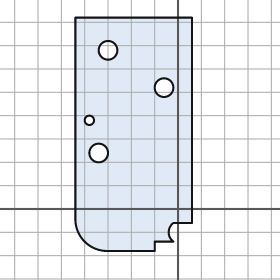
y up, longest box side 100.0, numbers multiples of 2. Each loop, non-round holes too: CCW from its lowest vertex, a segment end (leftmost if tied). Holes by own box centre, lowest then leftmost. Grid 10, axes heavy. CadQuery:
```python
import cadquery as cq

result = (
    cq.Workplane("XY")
    .moveTo(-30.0, -18.0)
    .lineTo(-10.0, -18.0)
    .lineTo(-10.0, -14.0)
    .lineTo(-2.0, -14.0)
    .threePointArc((-4.0, -10.0), (-2.0, -6.0))
    .lineTo(6.0, -6.0)
    .lineTo(6.0, 82.0)
    .lineTo(-44.0, 82.0)
    .lineTo(-44.0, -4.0)
    .threePointArc((-40.0, -14.0), (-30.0, -18.0))
    .close()
    .moveTo(-34.0, 24.0)
    .circle(4.0)
    .moveTo(-38.0, 38.0)
    .circle(2.0)
    .moveTo(-6.0, 52.0)
    .circle(4.0)
    .moveTo(-30.0, 68.0)
    .circle(4.0)
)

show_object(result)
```